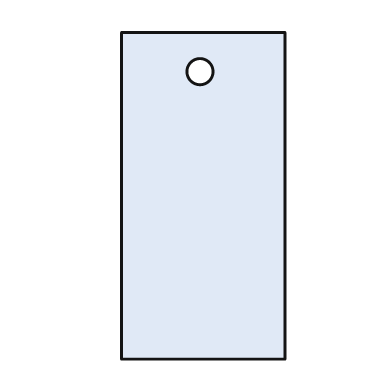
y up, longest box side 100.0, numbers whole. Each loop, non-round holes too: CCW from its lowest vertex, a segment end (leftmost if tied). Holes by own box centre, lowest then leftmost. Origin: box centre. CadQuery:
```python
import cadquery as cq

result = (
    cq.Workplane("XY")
    .moveTo(-25.0, -50.0)
    .lineTo(25.0, -50.0)
    .lineTo(25.0, 50.0)
    .lineTo(-25.0, 50.0)
    .close()
    .moveTo(-1.0, 38.0)
    .circle(4.0)
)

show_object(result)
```